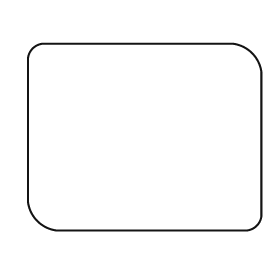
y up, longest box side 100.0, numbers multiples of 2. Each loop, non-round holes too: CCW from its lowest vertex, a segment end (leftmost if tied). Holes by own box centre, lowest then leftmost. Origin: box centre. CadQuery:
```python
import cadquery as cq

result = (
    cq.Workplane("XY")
    .moveTo(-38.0, -40.0)
    .lineTo(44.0, -40.0)
    .threePointArc((48.0, -38.0), (50.0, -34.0))
    .lineTo(50.0, 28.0)
    .threePointArc((46.0, 36.0), (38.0, 40.0))
    .lineTo(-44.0, 40.0)
    .threePointArc((-48.0, 38.0), (-50.0, 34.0))
    .lineTo(-50.0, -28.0)
    .threePointArc((-46.0, -36.0), (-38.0, -40.0))
    .close()
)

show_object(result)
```